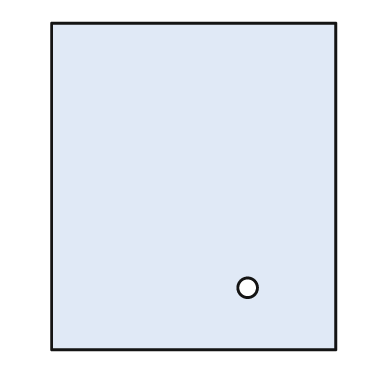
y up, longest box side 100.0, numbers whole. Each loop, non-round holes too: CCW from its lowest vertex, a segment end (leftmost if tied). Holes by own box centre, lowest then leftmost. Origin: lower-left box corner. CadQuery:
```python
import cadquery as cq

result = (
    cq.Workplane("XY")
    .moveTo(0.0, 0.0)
    .lineTo(87.0, 0.0)
    .lineTo(87.0, 100.0)
    .lineTo(0.0, 100.0)
    .close()
    .moveTo(60.0, 19.0)
    .circle(3.0)
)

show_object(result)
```